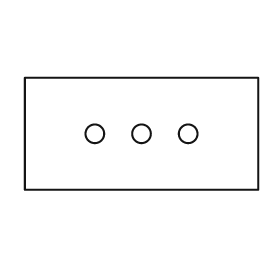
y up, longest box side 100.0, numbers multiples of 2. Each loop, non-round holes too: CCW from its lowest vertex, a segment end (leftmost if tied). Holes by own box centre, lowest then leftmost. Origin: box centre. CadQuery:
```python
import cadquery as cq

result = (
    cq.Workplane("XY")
    .moveTo(-50.0, -24.0)
    .lineTo(50.0, -24.0)
    .lineTo(50.0, 24.0)
    .lineTo(-50.0, 24.0)
    .close()
    .moveTo(-20.0, 0.0)
    .circle(4.0)
    .moveTo(0.0, 0.0)
    .circle(4.0)
    .moveTo(20.0, 0.0)
    .circle(4.0)
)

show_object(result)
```